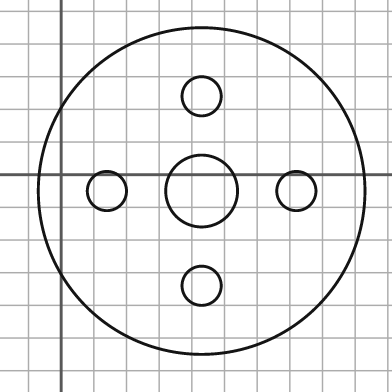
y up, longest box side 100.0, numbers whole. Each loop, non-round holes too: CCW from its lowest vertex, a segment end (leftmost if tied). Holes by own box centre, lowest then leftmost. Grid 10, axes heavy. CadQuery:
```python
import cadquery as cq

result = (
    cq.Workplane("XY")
    .moveTo(43.0, -5.0)
    .circle(50.0)
    .moveTo(43.0, -34.0)
    .circle(6.0)
    .moveTo(14.0, -5.0)
    .circle(6.0)
    .moveTo(43.0, -5.0)
    .circle(11.0)
    .moveTo(72.0, -5.0)
    .circle(6.0)
    .moveTo(43.0, 24.0)
    .circle(6.0)
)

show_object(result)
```